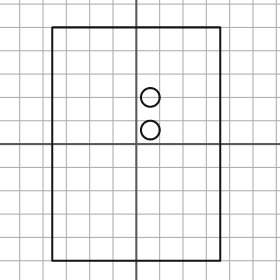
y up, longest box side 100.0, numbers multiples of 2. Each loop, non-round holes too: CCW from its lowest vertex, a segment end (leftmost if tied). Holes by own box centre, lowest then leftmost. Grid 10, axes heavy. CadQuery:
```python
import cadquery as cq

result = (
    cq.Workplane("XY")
    .moveTo(-36.0, -50.0)
    .lineTo(36.0, -50.0)
    .lineTo(36.0, 50.0)
    .lineTo(-36.0, 50.0)
    .close()
    .moveTo(6.0, 6.0)
    .circle(4.0)
    .moveTo(6.0, 20.0)
    .circle(4.0)
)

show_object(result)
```